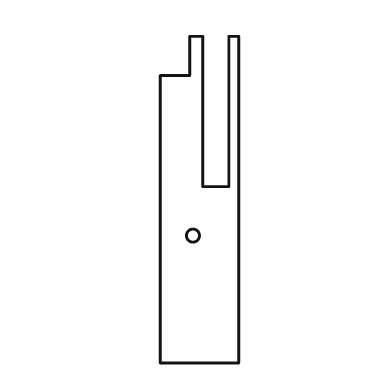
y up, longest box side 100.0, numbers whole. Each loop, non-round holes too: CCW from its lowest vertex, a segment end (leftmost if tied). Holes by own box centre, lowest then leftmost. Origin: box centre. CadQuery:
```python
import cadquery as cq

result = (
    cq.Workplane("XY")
    .moveTo(-12.0, -50.0)
    .lineTo(12.0, -50.0)
    .lineTo(12.0, 50.0)
    .lineTo(9.0, 50.0)
    .lineTo(9.0, 4.0)
    .lineTo(1.0, 4.0)
    .lineTo(1.0, 50.0)
    .lineTo(-3.0, 50.0)
    .lineTo(-3.0, 38.0)
    .lineTo(-12.0, 38.0)
    .close()
    .moveTo(-2.0, -11.0)
    .circle(2.0)
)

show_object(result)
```